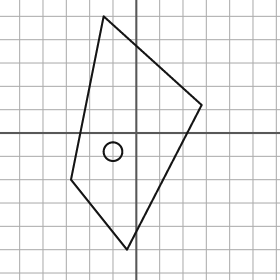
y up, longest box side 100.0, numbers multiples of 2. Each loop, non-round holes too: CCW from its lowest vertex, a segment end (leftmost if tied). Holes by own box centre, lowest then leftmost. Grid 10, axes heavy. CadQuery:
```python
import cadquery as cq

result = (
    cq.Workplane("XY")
    .moveTo(-4.0, -50.0)
    .lineTo(28.0, 12.0)
    .lineTo(-14.0, 50.0)
    .lineTo(-28.0, -20.0)
    .close()
    .moveTo(-10.0, -8.0)
    .circle(4.0)
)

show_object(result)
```